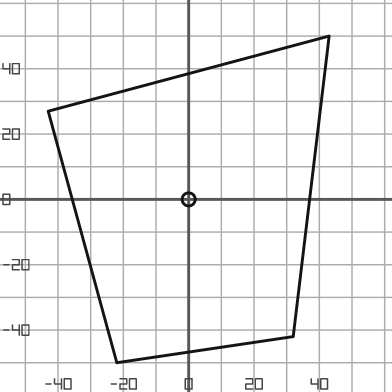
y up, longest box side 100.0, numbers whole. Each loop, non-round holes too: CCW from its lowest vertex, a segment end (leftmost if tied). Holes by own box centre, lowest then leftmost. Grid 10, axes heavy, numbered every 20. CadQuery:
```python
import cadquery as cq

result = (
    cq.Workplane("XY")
    .moveTo(-22.0, -50.0)
    .lineTo(32.0, -42.0)
    .lineTo(43.0, 50.0)
    .lineTo(-43.0, 27.0)
    .close()
    .moveTo(0.0, 0.0)
    .circle(2.0)
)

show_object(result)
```